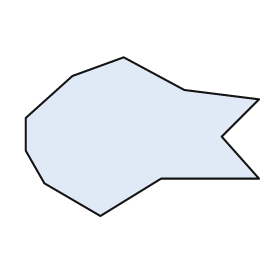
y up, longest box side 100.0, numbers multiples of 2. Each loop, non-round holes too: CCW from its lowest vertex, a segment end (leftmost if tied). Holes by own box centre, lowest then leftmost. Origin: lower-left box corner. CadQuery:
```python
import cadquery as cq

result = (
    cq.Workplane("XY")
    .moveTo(32.0, 0.0)
    .lineTo(58.0, 16.0)
    .lineTo(100.0, 16.0)
    .lineTo(84.0, 34.0)
    .lineTo(100.0, 50.0)
    .lineTo(68.0, 54.0)
    .lineTo(42.0, 68.0)
    .lineTo(20.0, 60.0)
    .lineTo(0.0, 42.0)
    .lineTo(0.0, 28.0)
    .lineTo(8.0, 14.0)
    .close()
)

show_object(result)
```